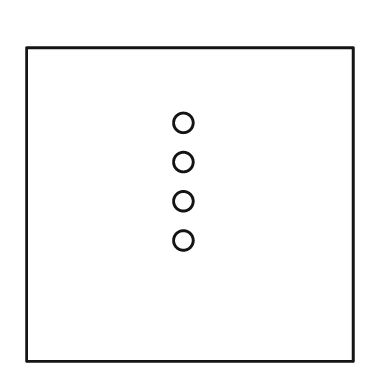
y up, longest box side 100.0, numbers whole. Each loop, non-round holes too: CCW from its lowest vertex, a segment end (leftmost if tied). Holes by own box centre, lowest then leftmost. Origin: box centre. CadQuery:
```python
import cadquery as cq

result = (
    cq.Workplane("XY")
    .moveTo(-50.0, -48.0)
    .lineTo(50.0, -48.0)
    .lineTo(50.0, 48.0)
    .lineTo(-50.0, 48.0)
    .close()
    .moveTo(-2.0, -11.0)
    .circle(3.0)
    .moveTo(-2.0, 1.0)
    .circle(3.0)
    .moveTo(-2.0, 13.0)
    .circle(3.0)
    .moveTo(-2.0, 25.0)
    .circle(3.0)
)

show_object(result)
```